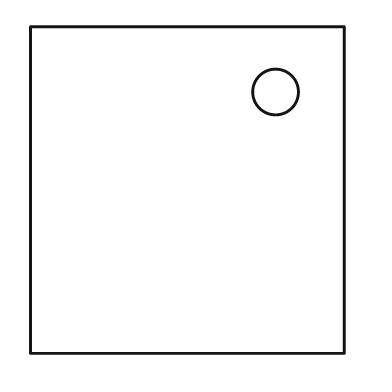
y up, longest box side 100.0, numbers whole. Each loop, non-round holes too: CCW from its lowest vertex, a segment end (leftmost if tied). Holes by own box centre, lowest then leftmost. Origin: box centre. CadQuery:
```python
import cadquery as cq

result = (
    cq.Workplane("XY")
    .moveTo(-48.0, -50.0)
    .lineTo(48.0, -50.0)
    .lineTo(48.0, 50.0)
    .lineTo(-48.0, 50.0)
    .close()
    .moveTo(27.0, 30.0)
    .circle(7.0)
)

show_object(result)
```